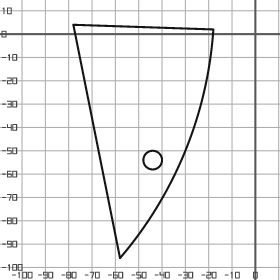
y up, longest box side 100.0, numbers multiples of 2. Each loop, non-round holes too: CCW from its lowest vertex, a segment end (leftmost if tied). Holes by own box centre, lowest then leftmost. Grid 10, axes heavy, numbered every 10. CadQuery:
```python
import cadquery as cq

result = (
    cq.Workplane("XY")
    .moveTo(-58.0, -96.0)
    .threePointArc((-30.0, -50.0), (-18.0, 2.0))
    .lineTo(-78.0, 4.0)
    .close()
    .moveTo(-44.0, -54.0)
    .circle(4.0)
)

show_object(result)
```